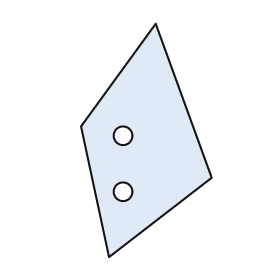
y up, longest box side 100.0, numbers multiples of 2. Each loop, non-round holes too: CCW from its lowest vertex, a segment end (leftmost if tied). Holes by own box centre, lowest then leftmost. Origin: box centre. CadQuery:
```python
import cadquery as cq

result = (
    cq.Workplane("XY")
    .moveTo(-16.0, -50.0)
    .lineTo(28.0, -16.0)
    .lineTo(4.0, 50.0)
    .lineTo(-28.0, 6.0)
    .close()
    .moveTo(-10.0, -22.0)
    .circle(4.0)
    .moveTo(-10.0, 2.0)
    .circle(4.0)
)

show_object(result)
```